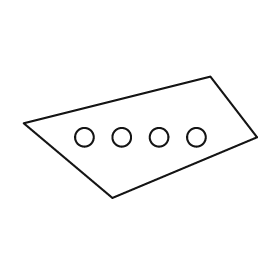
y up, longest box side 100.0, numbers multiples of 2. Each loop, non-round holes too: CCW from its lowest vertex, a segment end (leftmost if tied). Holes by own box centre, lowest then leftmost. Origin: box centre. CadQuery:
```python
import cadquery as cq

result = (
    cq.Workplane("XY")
    .moveTo(-12.0, -26.0)
    .lineTo(50.0, 0.0)
    .lineTo(30.0, 26.0)
    .lineTo(-50.0, 6.0)
    .close()
    .moveTo(-24.0, 0.0)
    .circle(4.0)
    .moveTo(-8.0, 0.0)
    .circle(4.0)
    .moveTo(8.0, 0.0)
    .circle(4.0)
    .moveTo(24.0, 0.0)
    .circle(4.0)
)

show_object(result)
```